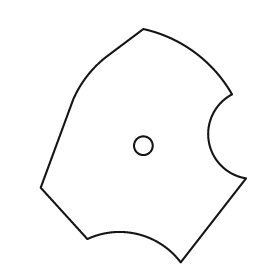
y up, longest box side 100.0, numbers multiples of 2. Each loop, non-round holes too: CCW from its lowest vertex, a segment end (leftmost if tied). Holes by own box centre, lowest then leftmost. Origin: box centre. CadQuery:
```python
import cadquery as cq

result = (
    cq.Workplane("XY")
    .moveTo(16.0, -50.0)
    .lineTo(44.0, -14.0)
    .threePointArc((28.0, 2.0), (38.0, 22.0))
    .threePointArc((22.0, 40.0), (0.0, 50.0))
    .lineTo(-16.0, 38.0)
    .threePointArc((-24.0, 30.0), (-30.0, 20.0))
    .lineTo(-44.0, -18.0)
    .lineTo(-24.0, -40.0)
    .threePointArc((-2.0, -38.0), (16.0, -50.0))
    .close()
    .moveTo(0.0, 0.0)
    .circle(4.0)
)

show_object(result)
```